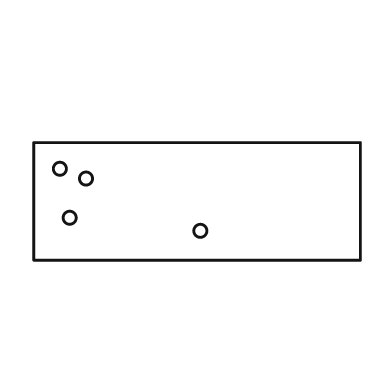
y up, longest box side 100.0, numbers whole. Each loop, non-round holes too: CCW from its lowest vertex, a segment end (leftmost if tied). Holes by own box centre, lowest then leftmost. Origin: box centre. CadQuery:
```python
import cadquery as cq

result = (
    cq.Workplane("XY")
    .moveTo(-50.0, -18.0)
    .lineTo(50.0, -18.0)
    .lineTo(50.0, 18.0)
    .lineTo(-50.0, 18.0)
    .close()
    .moveTo(1.0, -9.0)
    .circle(2.0)
    .moveTo(-39.0, -5.0)
    .circle(2.0)
    .moveTo(-34.0, 7.0)
    .circle(2.0)
    .moveTo(-42.0, 10.0)
    .circle(2.0)
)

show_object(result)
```